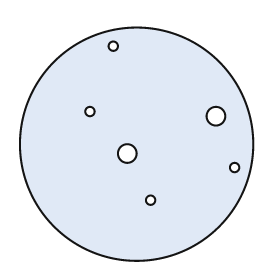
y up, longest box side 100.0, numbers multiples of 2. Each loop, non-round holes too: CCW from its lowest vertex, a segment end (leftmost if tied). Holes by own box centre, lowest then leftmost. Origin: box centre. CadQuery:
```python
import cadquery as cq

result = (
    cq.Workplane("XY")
    .moveTo(0.0, 0.0)
    .circle(50.0)
    .moveTo(6.0, -24.0)
    .circle(2.0)
    .moveTo(42.0, -10.0)
    .circle(2.0)
    .moveTo(-4.0, -4.0)
    .circle(4.0)
    .moveTo(34.0, 12.0)
    .circle(4.0)
    .moveTo(-20.0, 14.0)
    .circle(2.0)
    .moveTo(-10.0, 42.0)
    .circle(2.0)
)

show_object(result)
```